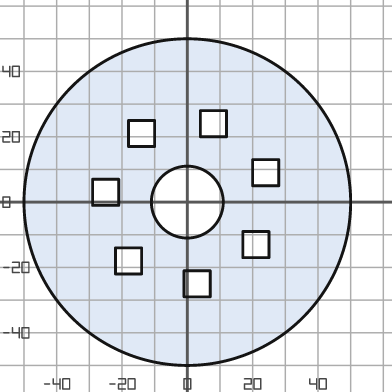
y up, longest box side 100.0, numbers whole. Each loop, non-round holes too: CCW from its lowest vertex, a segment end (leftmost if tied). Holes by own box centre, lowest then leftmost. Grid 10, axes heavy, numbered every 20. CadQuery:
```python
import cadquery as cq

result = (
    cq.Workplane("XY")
    .moveTo(0.0, 0.0)
    .circle(50.0)
    .moveTo(-1.0, -29.0)
    .lineTo(7.0, -29.0)
    .lineTo(7.0, -21.0)
    .lineTo(-1.0, -21.0)
    .close()
    .moveTo(-22.0, -22.0)
    .lineTo(-14.0, -22.0)
    .lineTo(-14.0, -14.0)
    .lineTo(-22.0, -14.0)
    .close()
    .moveTo(17.0, -17.0)
    .lineTo(25.0, -17.0)
    .lineTo(25.0, -9.0)
    .lineTo(17.0, -9.0)
    .close()
    .moveTo(0.0, 0.0)
    .circle(11.0)
    .moveTo(-29.0, -1.0)
    .lineTo(-21.0, -1.0)
    .lineTo(-21.0, 7.0)
    .lineTo(-29.0, 7.0)
    .close()
    .moveTo(20.0, 5.0)
    .lineTo(28.0, 5.0)
    .lineTo(28.0, 13.0)
    .lineTo(20.0, 13.0)
    .close()
    .moveTo(-18.0, 17.0)
    .lineTo(-10.0, 17.0)
    .lineTo(-10.0, 25.0)
    .lineTo(-18.0, 25.0)
    .close()
    .moveTo(4.0, 20.0)
    .lineTo(12.0, 20.0)
    .lineTo(12.0, 28.0)
    .lineTo(4.0, 28.0)
    .close()
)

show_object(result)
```